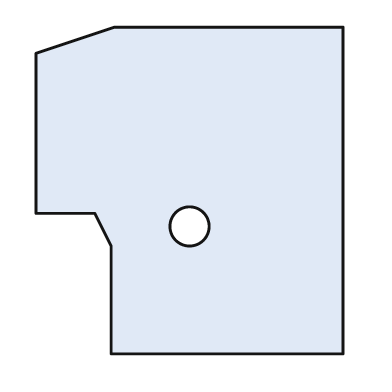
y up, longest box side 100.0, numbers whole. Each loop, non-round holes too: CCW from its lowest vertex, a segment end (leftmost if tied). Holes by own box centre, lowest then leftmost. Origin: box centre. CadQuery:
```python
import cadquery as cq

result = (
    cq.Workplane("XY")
    .moveTo(-24.0, -50.0)
    .lineTo(47.0, -50.0)
    .lineTo(47.0, 50.0)
    .lineTo(-23.0, 50.0)
    .lineTo(-47.0, 42.0)
    .lineTo(-47.0, -7.0)
    .lineTo(-29.0, -7.0)
    .lineTo(-24.0, -17.0)
    .close()
    .moveTo(0.0, -11.0)
    .circle(6.0)
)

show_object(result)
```